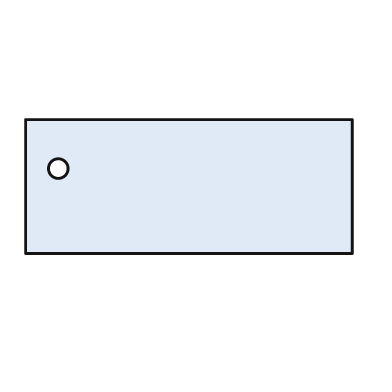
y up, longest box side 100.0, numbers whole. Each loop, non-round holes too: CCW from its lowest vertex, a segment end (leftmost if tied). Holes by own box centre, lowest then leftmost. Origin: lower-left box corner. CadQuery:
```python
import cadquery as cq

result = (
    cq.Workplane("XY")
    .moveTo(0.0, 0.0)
    .lineTo(100.0, 0.0)
    .lineTo(100.0, 41.0)
    .lineTo(0.0, 41.0)
    .close()
    .moveTo(10.0, 26.0)
    .circle(3.0)
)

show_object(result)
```